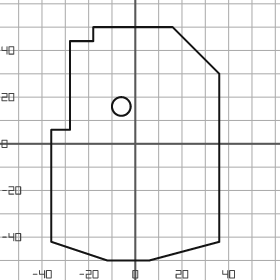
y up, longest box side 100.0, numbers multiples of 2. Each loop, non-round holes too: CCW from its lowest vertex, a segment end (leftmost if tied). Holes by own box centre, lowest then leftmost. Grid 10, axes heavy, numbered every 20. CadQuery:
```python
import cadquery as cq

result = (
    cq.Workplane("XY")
    .moveTo(-12.0, -50.0)
    .lineTo(6.0, -50.0)
    .lineTo(36.0, -42.0)
    .lineTo(36.0, 30.0)
    .lineTo(16.0, 50.0)
    .lineTo(-18.0, 50.0)
    .lineTo(-18.0, 44.0)
    .lineTo(-28.0, 44.0)
    .lineTo(-28.0, 6.0)
    .lineTo(-36.0, 6.0)
    .lineTo(-36.0, -42.0)
    .close()
    .moveTo(-6.0, 16.0)
    .circle(4.0)
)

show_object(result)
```